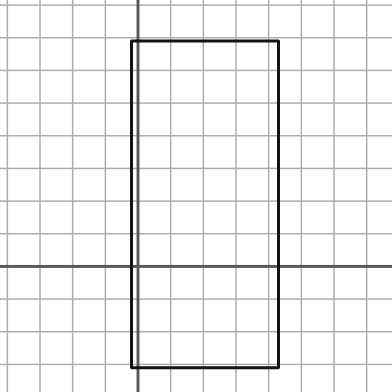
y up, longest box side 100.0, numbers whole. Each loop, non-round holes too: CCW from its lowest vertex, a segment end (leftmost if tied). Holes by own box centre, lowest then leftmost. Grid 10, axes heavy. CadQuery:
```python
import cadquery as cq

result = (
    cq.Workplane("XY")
    .moveTo(-2.0, -31.0)
    .lineTo(43.0, -31.0)
    .lineTo(43.0, 69.0)
    .lineTo(-2.0, 69.0)
    .close()
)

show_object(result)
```